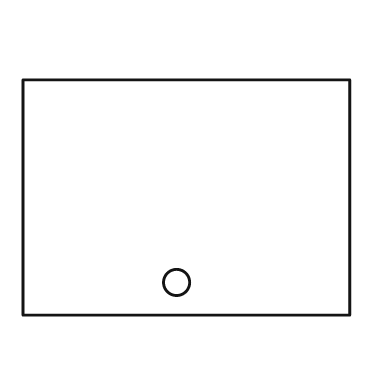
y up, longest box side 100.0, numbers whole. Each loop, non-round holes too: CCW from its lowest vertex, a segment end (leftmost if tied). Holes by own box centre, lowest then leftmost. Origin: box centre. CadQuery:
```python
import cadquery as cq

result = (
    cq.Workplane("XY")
    .moveTo(-50.0, -36.0)
    .lineTo(50.0, -36.0)
    .lineTo(50.0, 36.0)
    .lineTo(-50.0, 36.0)
    .close()
    .moveTo(-3.0, -26.0)
    .circle(4.0)
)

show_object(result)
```